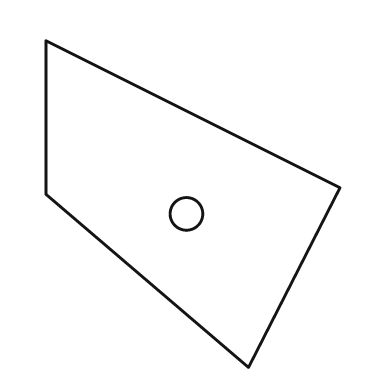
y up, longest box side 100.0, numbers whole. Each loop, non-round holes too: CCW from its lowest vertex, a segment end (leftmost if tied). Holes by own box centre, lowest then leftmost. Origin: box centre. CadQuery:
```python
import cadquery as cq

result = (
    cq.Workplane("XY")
    .moveTo(17.0, -50.0)
    .lineTo(45.0, 5.0)
    .lineTo(-45.0, 50.0)
    .lineTo(-45.0, 3.0)
    .close()
    .moveTo(-2.0, -3.0)
    .circle(5.0)
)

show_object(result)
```